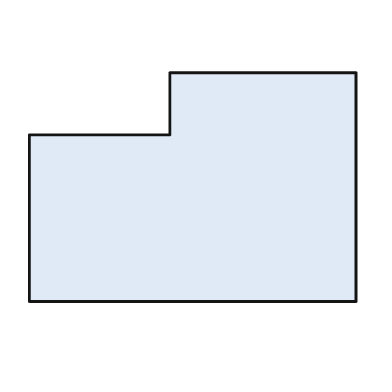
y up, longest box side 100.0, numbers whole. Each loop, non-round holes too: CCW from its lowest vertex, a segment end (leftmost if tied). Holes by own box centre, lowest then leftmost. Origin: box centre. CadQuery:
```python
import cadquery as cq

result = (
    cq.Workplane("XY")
    .moveTo(-50.0, -35.0)
    .lineTo(50.0, -35.0)
    .lineTo(50.0, 35.0)
    .lineTo(-7.0, 35.0)
    .lineTo(-7.0, 16.0)
    .lineTo(-50.0, 16.0)
    .close()
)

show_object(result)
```